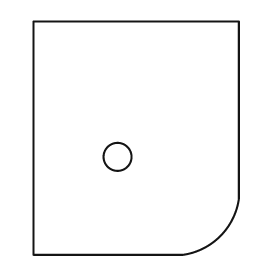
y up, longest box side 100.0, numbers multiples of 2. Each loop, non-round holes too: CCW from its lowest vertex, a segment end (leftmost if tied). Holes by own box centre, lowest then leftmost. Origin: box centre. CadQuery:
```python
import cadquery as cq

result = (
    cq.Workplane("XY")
    .moveTo(-44.0, -50.0)
    .lineTo(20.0, -50.0)
    .threePointArc((36.0, -42.0), (44.0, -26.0))
    .lineTo(44.0, 50.0)
    .lineTo(-44.0, 50.0)
    .close()
    .moveTo(-8.0, -8.0)
    .circle(6.0)
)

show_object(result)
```